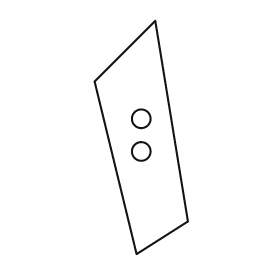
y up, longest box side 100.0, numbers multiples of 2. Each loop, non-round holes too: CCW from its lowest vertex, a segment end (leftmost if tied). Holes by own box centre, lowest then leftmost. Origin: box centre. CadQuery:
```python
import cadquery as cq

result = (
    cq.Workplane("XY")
    .moveTo(-2.0, -50.0)
    .lineTo(20.0, -36.0)
    .lineTo(6.0, 50.0)
    .lineTo(-20.0, 24.0)
    .close()
    .moveTo(0.0, -6.0)
    .circle(4.0)
    .moveTo(0.0, 8.0)
    .circle(4.0)
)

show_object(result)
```